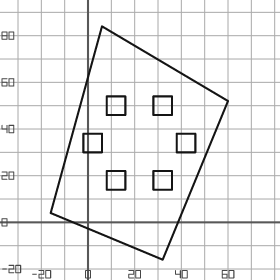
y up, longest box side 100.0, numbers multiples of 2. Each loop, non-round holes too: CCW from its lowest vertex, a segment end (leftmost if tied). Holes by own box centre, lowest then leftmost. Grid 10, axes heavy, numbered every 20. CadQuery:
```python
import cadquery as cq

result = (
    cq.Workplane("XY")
    .moveTo(32.0, -16.0)
    .lineTo(60.0, 52.0)
    .lineTo(6.0, 84.0)
    .lineTo(-16.0, 4.0)
    .close()
    .moveTo(8.0, 14.0)
    .lineTo(16.0, 14.0)
    .lineTo(16.0, 22.0)
    .lineTo(8.0, 22.0)
    .close()
    .moveTo(28.0, 14.0)
    .lineTo(36.0, 14.0)
    .lineTo(36.0, 22.0)
    .lineTo(28.0, 22.0)
    .close()
    .moveTo(-2.0, 30.0)
    .lineTo(6.0, 30.0)
    .lineTo(6.0, 38.0)
    .lineTo(-2.0, 38.0)
    .close()
    .moveTo(38.0, 30.0)
    .lineTo(46.0, 30.0)
    .lineTo(46.0, 38.0)
    .lineTo(38.0, 38.0)
    .close()
    .moveTo(8.0, 46.0)
    .lineTo(16.0, 46.0)
    .lineTo(16.0, 54.0)
    .lineTo(8.0, 54.0)
    .close()
    .moveTo(28.0, 46.0)
    .lineTo(36.0, 46.0)
    .lineTo(36.0, 54.0)
    .lineTo(28.0, 54.0)
    .close()
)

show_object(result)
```